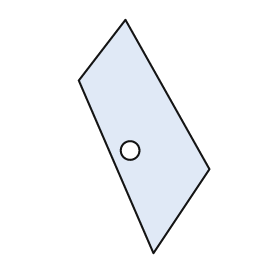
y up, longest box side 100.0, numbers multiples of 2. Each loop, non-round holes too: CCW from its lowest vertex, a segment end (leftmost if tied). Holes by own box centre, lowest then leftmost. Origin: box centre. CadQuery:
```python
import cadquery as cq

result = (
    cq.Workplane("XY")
    .moveTo(4.0, -50.0)
    .lineTo(28.0, -14.0)
    .lineTo(-8.0, 50.0)
    .lineTo(-28.0, 24.0)
    .close()
    .moveTo(-6.0, -6.0)
    .circle(4.0)
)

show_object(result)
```